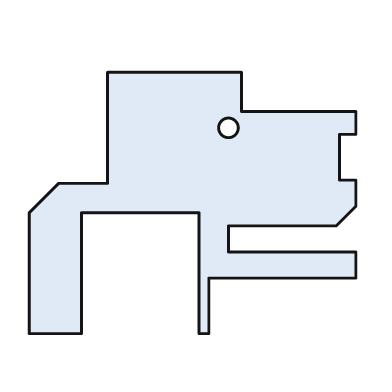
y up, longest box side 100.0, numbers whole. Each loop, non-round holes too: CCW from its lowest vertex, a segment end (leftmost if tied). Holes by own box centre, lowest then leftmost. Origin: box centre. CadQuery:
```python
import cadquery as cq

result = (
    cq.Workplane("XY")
    .moveTo(-50.0, -40.0)
    .lineTo(-34.0, -40.0)
    .lineTo(-34.0, -3.0)
    .lineTo(2.0, -3.0)
    .lineTo(2.0, -40.0)
    .lineTo(5.0, -40.0)
    .lineTo(5.0, -23.0)
    .lineTo(50.0, -23.0)
    .lineTo(50.0, -15.0)
    .lineTo(11.0, -15.0)
    .lineTo(11.0, -7.0)
    .lineTo(44.0, -7.0)
    .lineTo(50.0, -1.0)
    .lineTo(50.0, 7.0)
    .lineTo(45.0, 7.0)
    .lineTo(45.0, 21.0)
    .lineTo(50.0, 21.0)
    .lineTo(50.0, 28.0)
    .lineTo(15.0, 28.0)
    .lineTo(15.0, 40.0)
    .lineTo(-26.0, 40.0)
    .lineTo(-26.0, 6.0)
    .lineTo(-41.0, 6.0)
    .lineTo(-50.0, -3.0)
    .close()
    .moveTo(11.0, 23.0)
    .circle(3.0)
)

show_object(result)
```